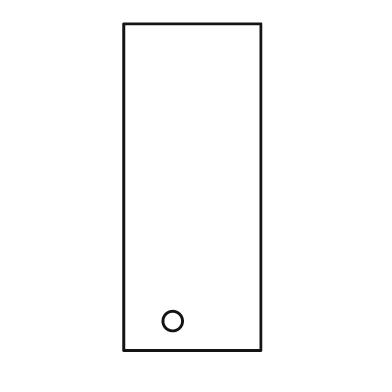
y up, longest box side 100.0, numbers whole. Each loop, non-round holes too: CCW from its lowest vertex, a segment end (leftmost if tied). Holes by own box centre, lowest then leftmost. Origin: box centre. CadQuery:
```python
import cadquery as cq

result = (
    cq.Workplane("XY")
    .moveTo(-21.0, -50.0)
    .lineTo(21.0, -50.0)
    .lineTo(21.0, 50.0)
    .lineTo(-21.0, 50.0)
    .close()
    .moveTo(-6.0, -41.0)
    .circle(3.0)
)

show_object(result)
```